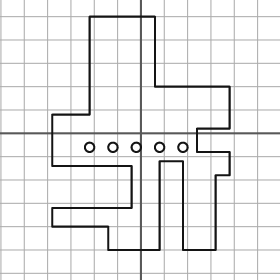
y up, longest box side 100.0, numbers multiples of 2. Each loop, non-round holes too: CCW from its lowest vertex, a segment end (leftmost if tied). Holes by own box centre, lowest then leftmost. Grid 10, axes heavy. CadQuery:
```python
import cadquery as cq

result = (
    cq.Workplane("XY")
    .moveTo(-14.0, -50.0)
    .lineTo(8.0, -50.0)
    .lineTo(8.0, -12.0)
    .lineTo(18.0, -12.0)
    .lineTo(18.0, -50.0)
    .lineTo(32.0, -50.0)
    .lineTo(32.0, -18.0)
    .lineTo(38.0, -18.0)
    .lineTo(38.0, -8.0)
    .lineTo(24.0, -8.0)
    .lineTo(24.0, 2.0)
    .lineTo(38.0, 2.0)
    .lineTo(38.0, 20.0)
    .lineTo(6.0, 20.0)
    .lineTo(6.0, 50.0)
    .lineTo(-22.0, 50.0)
    .lineTo(-22.0, 8.0)
    .lineTo(-38.0, 8.0)
    .lineTo(-38.0, -14.0)
    .lineTo(-4.0, -14.0)
    .lineTo(-4.0, -32.0)
    .lineTo(-38.0, -32.0)
    .lineTo(-38.0, -40.0)
    .lineTo(-14.0, -40.0)
    .close()
    .moveTo(-22.0, -6.0)
    .circle(2.0)
    .moveTo(-12.0, -6.0)
    .circle(2.0)
    .moveTo(-2.0, -6.0)
    .circle(2.0)
    .moveTo(8.0, -6.0)
    .circle(2.0)
    .moveTo(18.0, -6.0)
    .circle(2.0)
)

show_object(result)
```